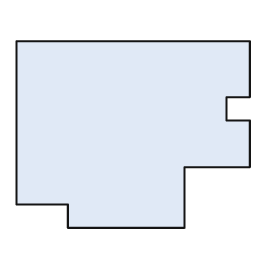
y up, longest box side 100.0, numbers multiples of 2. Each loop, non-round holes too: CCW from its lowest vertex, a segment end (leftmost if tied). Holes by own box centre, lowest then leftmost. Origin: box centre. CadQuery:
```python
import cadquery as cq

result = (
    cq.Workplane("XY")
    .moveTo(-28.0, -40.0)
    .lineTo(22.0, -40.0)
    .lineTo(22.0, -14.0)
    .lineTo(50.0, -14.0)
    .lineTo(50.0, 6.0)
    .lineTo(40.0, 6.0)
    .lineTo(40.0, 16.0)
    .lineTo(50.0, 16.0)
    .lineTo(50.0, 40.0)
    .lineTo(-50.0, 40.0)
    .lineTo(-50.0, -30.0)
    .lineTo(-28.0, -30.0)
    .close()
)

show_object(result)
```